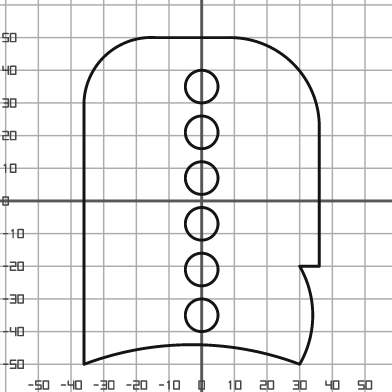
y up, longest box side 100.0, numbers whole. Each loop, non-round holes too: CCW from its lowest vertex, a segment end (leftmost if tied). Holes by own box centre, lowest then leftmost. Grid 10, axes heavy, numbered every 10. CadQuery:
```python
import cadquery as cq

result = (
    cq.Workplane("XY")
    .moveTo(-36.0, -50.0)
    .threePointArc((-3.0, -44.0), (30.0, -50.0))
    .threePointArc((34.0, -35.0), (30.0, -20.0))
    .lineTo(36.0, -20.0)
    .lineTo(36.0, 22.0)
    .threePointArc((28.0, 42.0), (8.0, 50.0))
    .lineTo(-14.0, 50.0)
    .threePointArc((-30.0, 44.0), (-36.0, 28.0))
    .close()
    .moveTo(0.0, -35.0)
    .circle(5.0)
    .moveTo(0.0, -21.0)
    .circle(5.0)
    .moveTo(0.0, -7.0)
    .circle(5.0)
    .moveTo(0.0, 7.0)
    .circle(5.0)
    .moveTo(0.0, 21.0)
    .circle(5.0)
    .moveTo(0.0, 35.0)
    .circle(5.0)
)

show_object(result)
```